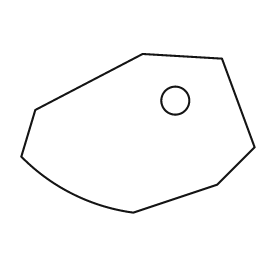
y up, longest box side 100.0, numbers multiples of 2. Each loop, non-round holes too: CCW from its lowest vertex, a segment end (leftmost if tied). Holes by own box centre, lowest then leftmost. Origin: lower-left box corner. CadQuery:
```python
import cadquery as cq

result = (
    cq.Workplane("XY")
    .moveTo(48.0, 0.0)
    .lineTo(84.0, 12.0)
    .lineTo(100.0, 28.0)
    .lineTo(86.0, 66.0)
    .lineTo(52.0, 68.0)
    .lineTo(6.0, 44.0)
    .lineTo(0.0, 24.0)
    .threePointArc((22.0, 8.0), (48.0, 0.0))
    .close()
    .moveTo(66.0, 48.0)
    .circle(6.0)
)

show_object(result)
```